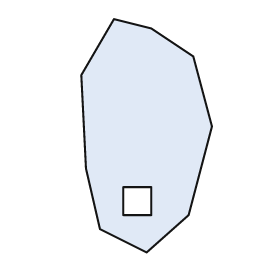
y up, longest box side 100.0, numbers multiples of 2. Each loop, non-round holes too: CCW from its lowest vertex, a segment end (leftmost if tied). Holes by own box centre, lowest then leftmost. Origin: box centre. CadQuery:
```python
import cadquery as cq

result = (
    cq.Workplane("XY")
    .moveTo(0.0, -50.0)
    .lineTo(18.0, -34.0)
    .lineTo(28.0, 4.0)
    .lineTo(20.0, 34.0)
    .lineTo(2.0, 46.0)
    .lineTo(-14.0, 50.0)
    .lineTo(-28.0, 26.0)
    .lineTo(-26.0, -14.0)
    .lineTo(-20.0, -40.0)
    .close()
    .moveTo(-10.0, -34.0)
    .lineTo(2.0, -34.0)
    .lineTo(2.0, -22.0)
    .lineTo(-10.0, -22.0)
    .close()
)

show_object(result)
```